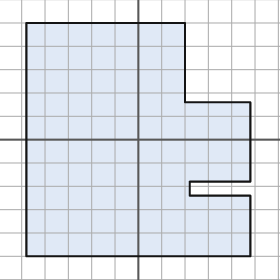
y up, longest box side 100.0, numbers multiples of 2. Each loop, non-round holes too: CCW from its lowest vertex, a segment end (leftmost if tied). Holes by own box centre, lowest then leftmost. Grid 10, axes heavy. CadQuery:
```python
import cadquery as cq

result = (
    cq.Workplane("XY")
    .moveTo(-48.0, -50.0)
    .lineTo(48.0, -50.0)
    .lineTo(48.0, -24.0)
    .lineTo(22.0, -24.0)
    .lineTo(22.0, -18.0)
    .lineTo(48.0, -18.0)
    .lineTo(48.0, 16.0)
    .lineTo(20.0, 16.0)
    .lineTo(20.0, 50.0)
    .lineTo(-48.0, 50.0)
    .close()
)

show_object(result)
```